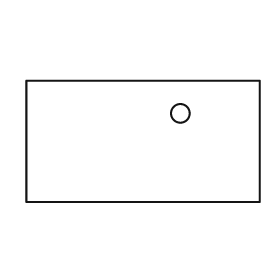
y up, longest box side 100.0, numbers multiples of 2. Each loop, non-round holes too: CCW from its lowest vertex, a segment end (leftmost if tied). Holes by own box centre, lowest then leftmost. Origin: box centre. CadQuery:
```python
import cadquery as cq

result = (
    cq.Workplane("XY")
    .moveTo(-50.0, -26.0)
    .lineTo(50.0, -26.0)
    .lineTo(50.0, 26.0)
    .lineTo(-50.0, 26.0)
    .close()
    .moveTo(16.0, 12.0)
    .circle(4.0)
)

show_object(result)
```